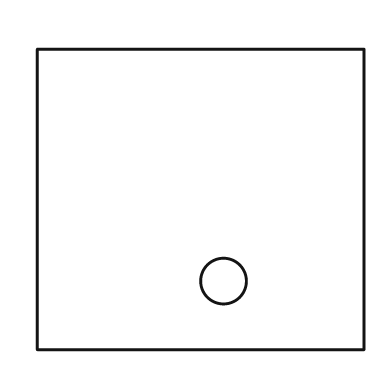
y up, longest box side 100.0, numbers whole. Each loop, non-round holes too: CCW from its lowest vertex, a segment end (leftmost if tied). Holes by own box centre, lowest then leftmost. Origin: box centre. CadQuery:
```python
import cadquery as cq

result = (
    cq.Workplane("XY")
    .moveTo(-50.0, -46.0)
    .lineTo(50.0, -46.0)
    .lineTo(50.0, 46.0)
    .lineTo(-50.0, 46.0)
    .close()
    .moveTo(7.0, -25.0)
    .circle(7.0)
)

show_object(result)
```